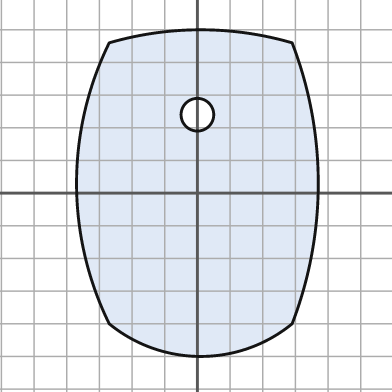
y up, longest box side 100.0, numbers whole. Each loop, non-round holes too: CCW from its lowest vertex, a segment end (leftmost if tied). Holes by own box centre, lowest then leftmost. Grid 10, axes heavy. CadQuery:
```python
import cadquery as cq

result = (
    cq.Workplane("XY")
    .moveTo(-27.0, -40.0)
    .threePointArc((1.0, -50.0), (29.0, -40.0))
    .threePointArc((37.0, 3.0), (29.0, 46.0))
    .threePointArc((1.0, 50.0), (-27.0, 46.0))
    .threePointArc((-37.0, 3.0), (-27.0, -40.0))
    .close()
    .moveTo(0.0, 24.0)
    .circle(5.0)
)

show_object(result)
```